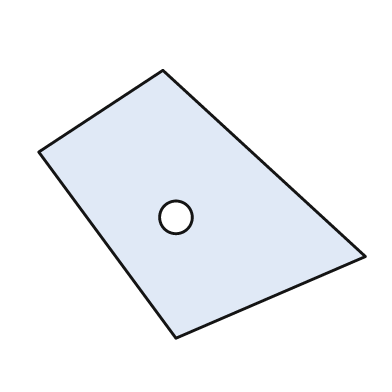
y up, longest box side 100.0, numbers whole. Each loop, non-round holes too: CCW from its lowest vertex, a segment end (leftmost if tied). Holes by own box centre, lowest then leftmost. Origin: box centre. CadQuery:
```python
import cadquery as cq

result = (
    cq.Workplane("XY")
    .moveTo(-8.0, -41.0)
    .lineTo(50.0, -16.0)
    .lineTo(-12.0, 41.0)
    .lineTo(-50.0, 16.0)
    .close()
    .moveTo(-8.0, -4.0)
    .circle(5.0)
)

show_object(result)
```